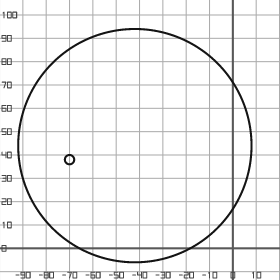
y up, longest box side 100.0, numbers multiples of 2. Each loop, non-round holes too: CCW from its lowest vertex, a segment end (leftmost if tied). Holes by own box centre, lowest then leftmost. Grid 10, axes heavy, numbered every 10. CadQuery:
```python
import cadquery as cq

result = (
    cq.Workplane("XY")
    .moveTo(-42.0, 44.0)
    .circle(50.0)
    .moveTo(-70.0, 38.0)
    .circle(2.0)
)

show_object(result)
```